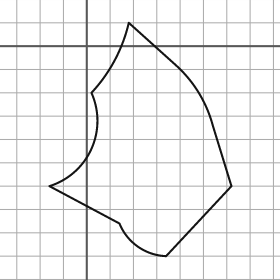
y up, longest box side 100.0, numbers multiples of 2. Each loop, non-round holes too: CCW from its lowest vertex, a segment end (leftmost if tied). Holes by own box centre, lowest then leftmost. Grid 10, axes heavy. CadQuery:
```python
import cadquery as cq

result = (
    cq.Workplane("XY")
    .moveTo(34.0, -90.0)
    .lineTo(62.0, -60.0)
    .lineTo(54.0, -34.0)
    .threePointArc((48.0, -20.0), (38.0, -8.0))
    .lineTo(18.0, 10.0)
    .threePointArc((12.0, -6.0), (2.0, -20.0))
    .threePointArc((2.0, -44.0), (-16.0, -60.0))
    .lineTo(14.0, -76.0)
    .threePointArc((22.0, -86.0), (34.0, -90.0))
    .close()
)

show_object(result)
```